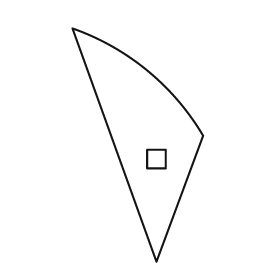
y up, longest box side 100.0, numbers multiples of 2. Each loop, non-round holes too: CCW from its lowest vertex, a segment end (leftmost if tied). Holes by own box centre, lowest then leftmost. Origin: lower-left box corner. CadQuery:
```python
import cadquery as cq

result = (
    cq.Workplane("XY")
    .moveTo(36.0, 0.0)
    .lineTo(56.0, 54.0)
    .threePointArc((32.0, 82.0), (0.0, 100.0))
    .close()
    .moveTo(32.0, 40.0)
    .lineTo(40.0, 40.0)
    .lineTo(40.0, 48.0)
    .lineTo(32.0, 48.0)
    .close()
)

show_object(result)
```